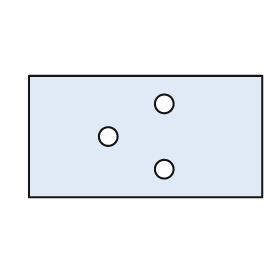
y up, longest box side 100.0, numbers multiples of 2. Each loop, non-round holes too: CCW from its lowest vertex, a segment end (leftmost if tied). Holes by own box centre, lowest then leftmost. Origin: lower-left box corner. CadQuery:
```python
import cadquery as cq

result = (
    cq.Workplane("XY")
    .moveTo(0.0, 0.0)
    .lineTo(100.0, 0.0)
    .lineTo(100.0, 52.0)
    .lineTo(0.0, 52.0)
    .close()
    .moveTo(58.0, 12.0)
    .circle(4.0)
    .moveTo(34.0, 26.0)
    .circle(4.0)
    .moveTo(58.0, 40.0)
    .circle(4.0)
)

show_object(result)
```